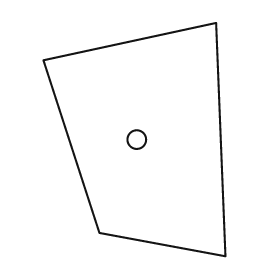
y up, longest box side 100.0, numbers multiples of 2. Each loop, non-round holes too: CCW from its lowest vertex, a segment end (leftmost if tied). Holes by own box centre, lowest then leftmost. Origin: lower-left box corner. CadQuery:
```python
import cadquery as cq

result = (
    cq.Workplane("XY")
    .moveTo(78.0, 0.0)
    .lineTo(74.0, 100.0)
    .lineTo(0.0, 84.0)
    .lineTo(24.0, 10.0)
    .close()
    .moveTo(40.0, 50.0)
    .circle(4.0)
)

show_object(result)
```